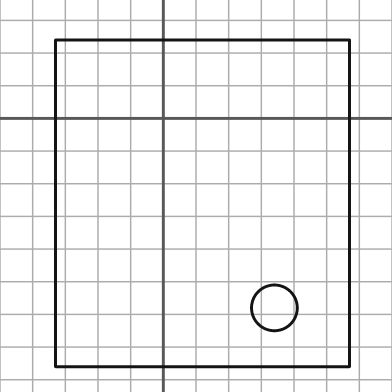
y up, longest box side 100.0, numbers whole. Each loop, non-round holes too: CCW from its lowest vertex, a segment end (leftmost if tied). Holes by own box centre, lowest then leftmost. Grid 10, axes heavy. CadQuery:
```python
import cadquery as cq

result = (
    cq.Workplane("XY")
    .moveTo(-33.0, -76.0)
    .lineTo(57.0, -76.0)
    .lineTo(57.0, 24.0)
    .lineTo(-33.0, 24.0)
    .close()
    .moveTo(34.0, -58.0)
    .circle(7.0)
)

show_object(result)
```